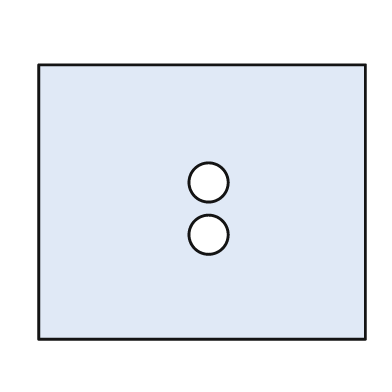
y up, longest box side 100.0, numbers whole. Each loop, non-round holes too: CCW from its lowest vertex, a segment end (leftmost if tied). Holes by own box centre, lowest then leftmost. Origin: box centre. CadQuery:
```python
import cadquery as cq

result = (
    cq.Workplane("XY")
    .moveTo(-50.0, -42.0)
    .lineTo(50.0, -42.0)
    .lineTo(50.0, 42.0)
    .lineTo(-50.0, 42.0)
    .close()
    .moveTo(2.0, -10.0)
    .circle(6.0)
    .moveTo(2.0, 6.0)
    .circle(6.0)
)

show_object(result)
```